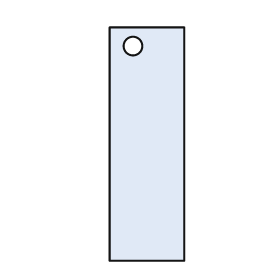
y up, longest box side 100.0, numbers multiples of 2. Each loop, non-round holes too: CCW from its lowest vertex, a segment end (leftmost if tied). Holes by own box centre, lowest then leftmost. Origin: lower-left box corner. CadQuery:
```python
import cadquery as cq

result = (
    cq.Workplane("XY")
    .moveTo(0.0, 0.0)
    .lineTo(32.0, 0.0)
    .lineTo(32.0, 100.0)
    .lineTo(0.0, 100.0)
    .close()
    .moveTo(10.0, 92.0)
    .circle(4.0)
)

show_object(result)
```